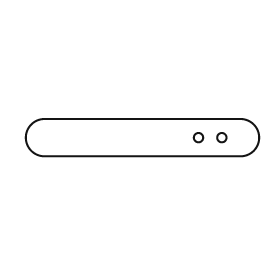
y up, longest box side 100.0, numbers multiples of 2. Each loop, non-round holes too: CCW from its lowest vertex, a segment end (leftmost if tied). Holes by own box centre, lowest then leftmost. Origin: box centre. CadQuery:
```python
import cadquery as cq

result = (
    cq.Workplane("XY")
    .moveTo(-42.0, -8.0)
    .lineTo(42.0, -8.0)
    .threePointArc((50.0, 0.0), (42.0, 8.0))
    .lineTo(-42.0, 8.0)
    .threePointArc((-50.0, 0.0), (-42.0, -8.0))
    .close()
    .moveTo(24.0, 0.0)
    .circle(2.0)
    .moveTo(34.0, 0.0)
    .circle(2.0)
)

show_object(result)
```